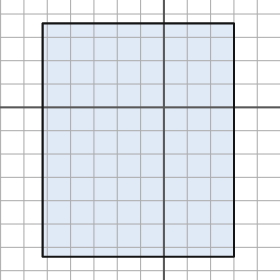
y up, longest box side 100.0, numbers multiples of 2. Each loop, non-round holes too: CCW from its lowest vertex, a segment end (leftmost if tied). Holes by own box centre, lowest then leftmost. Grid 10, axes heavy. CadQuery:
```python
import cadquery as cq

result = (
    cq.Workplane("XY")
    .moveTo(-52.0, -64.0)
    .lineTo(30.0, -64.0)
    .lineTo(30.0, 36.0)
    .lineTo(-52.0, 36.0)
    .close()
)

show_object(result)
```